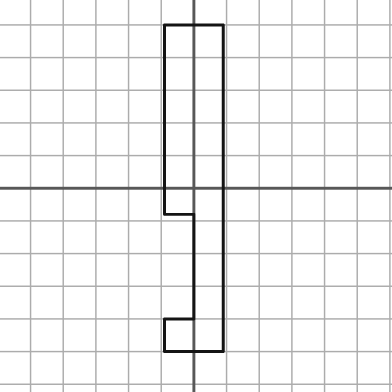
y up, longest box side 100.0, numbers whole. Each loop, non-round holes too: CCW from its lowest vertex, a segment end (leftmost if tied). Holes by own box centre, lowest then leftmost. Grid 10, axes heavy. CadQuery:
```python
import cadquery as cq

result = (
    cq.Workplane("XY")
    .moveTo(-9.0, -50.0)
    .lineTo(9.0, -50.0)
    .lineTo(9.0, 50.0)
    .lineTo(-9.0, 50.0)
    .lineTo(-9.0, -8.0)
    .lineTo(0.0, -8.0)
    .lineTo(0.0, -40.0)
    .lineTo(-9.0, -40.0)
    .close()
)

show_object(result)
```